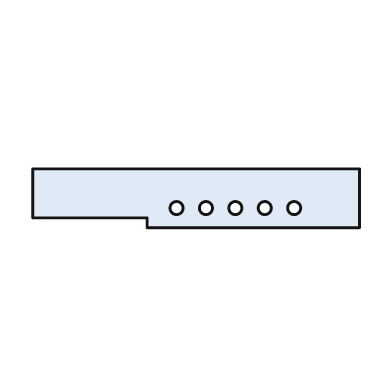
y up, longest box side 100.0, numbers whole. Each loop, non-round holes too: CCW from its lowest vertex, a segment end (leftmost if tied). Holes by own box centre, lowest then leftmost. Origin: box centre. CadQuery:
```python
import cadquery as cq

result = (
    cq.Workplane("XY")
    .moveTo(-15.0, -9.0)
    .lineTo(50.0, -9.0)
    .lineTo(50.0, 9.0)
    .lineTo(-50.0, 9.0)
    .lineTo(-50.0, -6.0)
    .lineTo(-15.0, -6.0)
    .close()
    .moveTo(-6.0, -3.0)
    .circle(2.0)
    .moveTo(3.0, -3.0)
    .circle(2.0)
    .moveTo(12.0, -3.0)
    .circle(2.0)
    .moveTo(21.0, -3.0)
    .circle(2.0)
    .moveTo(30.0, -3.0)
    .circle(2.0)
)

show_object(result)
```